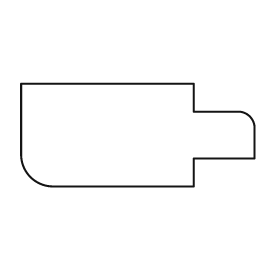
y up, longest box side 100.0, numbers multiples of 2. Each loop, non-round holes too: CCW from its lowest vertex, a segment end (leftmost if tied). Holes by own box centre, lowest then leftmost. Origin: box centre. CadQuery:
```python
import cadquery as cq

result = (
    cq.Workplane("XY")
    .moveTo(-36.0, -22.0)
    .lineTo(24.0, -22.0)
    .lineTo(24.0, -10.0)
    .lineTo(50.0, -10.0)
    .lineTo(50.0, 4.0)
    .threePointArc((48.0, 8.0), (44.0, 10.0))
    .lineTo(24.0, 10.0)
    .lineTo(24.0, 22.0)
    .lineTo(-50.0, 22.0)
    .lineTo(-50.0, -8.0)
    .threePointArc((-46.0, -18.0), (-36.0, -22.0))
    .close()
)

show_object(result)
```